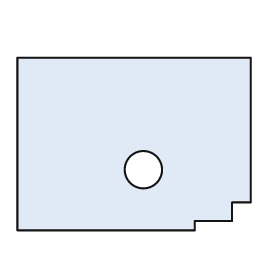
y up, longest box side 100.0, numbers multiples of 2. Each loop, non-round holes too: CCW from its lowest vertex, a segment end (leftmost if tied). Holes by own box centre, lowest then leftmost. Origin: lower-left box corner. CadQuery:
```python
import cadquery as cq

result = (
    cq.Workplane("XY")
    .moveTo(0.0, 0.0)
    .lineTo(76.0, 0.0)
    .lineTo(76.0, 4.0)
    .lineTo(92.0, 4.0)
    .lineTo(92.0, 12.0)
    .lineTo(100.0, 12.0)
    .lineTo(100.0, 74.0)
    .lineTo(0.0, 74.0)
    .close()
    .moveTo(54.0, 26.0)
    .circle(8.0)
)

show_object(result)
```